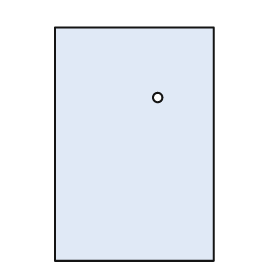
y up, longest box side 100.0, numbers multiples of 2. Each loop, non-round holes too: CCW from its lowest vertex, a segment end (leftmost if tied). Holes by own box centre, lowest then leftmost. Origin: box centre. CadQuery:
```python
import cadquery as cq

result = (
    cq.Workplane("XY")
    .moveTo(-34.0, -50.0)
    .lineTo(34.0, -50.0)
    .lineTo(34.0, 50.0)
    .lineTo(-34.0, 50.0)
    .close()
    .moveTo(10.0, 20.0)
    .circle(2.0)
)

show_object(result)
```